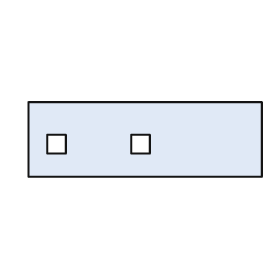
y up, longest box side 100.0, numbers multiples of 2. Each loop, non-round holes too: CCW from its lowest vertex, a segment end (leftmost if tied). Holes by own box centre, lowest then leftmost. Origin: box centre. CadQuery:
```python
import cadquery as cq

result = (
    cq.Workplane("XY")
    .moveTo(-50.0, -16.0)
    .lineTo(50.0, -16.0)
    .lineTo(50.0, 16.0)
    .lineTo(-50.0, 16.0)
    .close()
    .moveTo(-42.0, -6.0)
    .lineTo(-34.0, -6.0)
    .lineTo(-34.0, 2.0)
    .lineTo(-42.0, 2.0)
    .close()
    .moveTo(-6.0, -6.0)
    .lineTo(2.0, -6.0)
    .lineTo(2.0, 2.0)
    .lineTo(-6.0, 2.0)
    .close()
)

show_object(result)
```